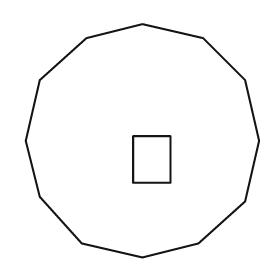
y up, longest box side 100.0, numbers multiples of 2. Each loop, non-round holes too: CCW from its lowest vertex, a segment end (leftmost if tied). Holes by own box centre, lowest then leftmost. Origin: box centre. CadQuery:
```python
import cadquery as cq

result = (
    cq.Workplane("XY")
    .moveTo(0.0, -50.0)
    .lineTo(24.0, -44.0)
    .lineTo(44.0, -26.0)
    .lineTo(50.0, 0.0)
    .lineTo(44.0, 26.0)
    .lineTo(26.0, 44.0)
    .lineTo(0.0, 50.0)
    .lineTo(-24.0, 44.0)
    .lineTo(-44.0, 26.0)
    .lineTo(-50.0, 0.0)
    .lineTo(-44.0, -24.0)
    .lineTo(-26.0, -44.0)
    .close()
    .moveTo(-4.0, -18.0)
    .lineTo(12.0, -18.0)
    .lineTo(12.0, 2.0)
    .lineTo(-4.0, 2.0)
    .close()
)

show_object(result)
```